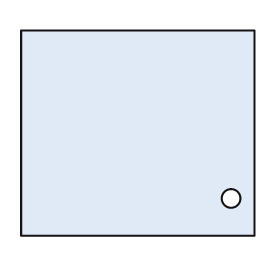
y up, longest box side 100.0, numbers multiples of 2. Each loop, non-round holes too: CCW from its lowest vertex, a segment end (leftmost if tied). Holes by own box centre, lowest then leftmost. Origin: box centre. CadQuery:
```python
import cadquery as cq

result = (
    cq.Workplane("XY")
    .moveTo(-50.0, -44.0)
    .lineTo(50.0, -44.0)
    .lineTo(50.0, 44.0)
    .lineTo(-50.0, 44.0)
    .close()
    .moveTo(40.0, -28.0)
    .circle(4.0)
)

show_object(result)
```